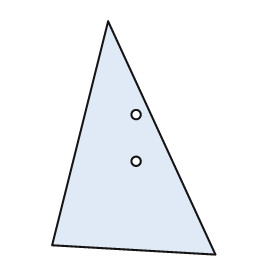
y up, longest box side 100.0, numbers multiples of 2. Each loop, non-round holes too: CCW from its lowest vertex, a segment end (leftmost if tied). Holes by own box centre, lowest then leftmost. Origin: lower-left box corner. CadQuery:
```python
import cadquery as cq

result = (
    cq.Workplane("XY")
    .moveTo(70.0, 0.0)
    .lineTo(24.0, 100.0)
    .lineTo(0.0, 4.0)
    .close()
    .moveTo(36.0, 40.0)
    .circle(2.0)
    .moveTo(36.0, 60.0)
    .circle(2.0)
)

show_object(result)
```